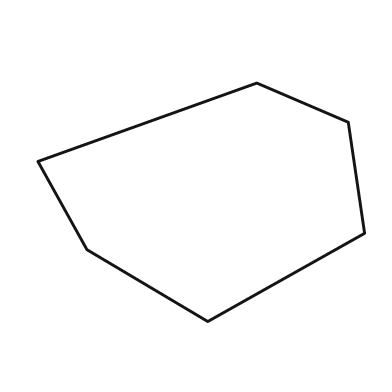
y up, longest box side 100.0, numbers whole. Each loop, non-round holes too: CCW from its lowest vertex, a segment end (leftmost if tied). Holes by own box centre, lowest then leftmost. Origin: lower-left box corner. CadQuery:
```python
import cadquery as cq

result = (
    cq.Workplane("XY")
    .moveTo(52.0, 0.0)
    .lineTo(100.0, 27.0)
    .lineTo(95.0, 61.0)
    .lineTo(67.0, 73.0)
    .lineTo(0.0, 49.0)
    .lineTo(15.0, 22.0)
    .close()
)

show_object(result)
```